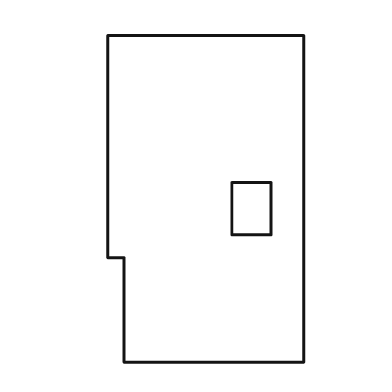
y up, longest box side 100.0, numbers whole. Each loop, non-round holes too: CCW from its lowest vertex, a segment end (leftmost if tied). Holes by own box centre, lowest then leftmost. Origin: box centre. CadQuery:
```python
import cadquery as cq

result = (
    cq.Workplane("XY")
    .moveTo(-25.0, -50.0)
    .lineTo(30.0, -50.0)
    .lineTo(30.0, 50.0)
    .lineTo(-30.0, 50.0)
    .lineTo(-30.0, -18.0)
    .lineTo(-25.0, -18.0)
    .close()
    .moveTo(8.0, -11.0)
    .lineTo(20.0, -11.0)
    .lineTo(20.0, 5.0)
    .lineTo(8.0, 5.0)
    .close()
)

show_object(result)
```